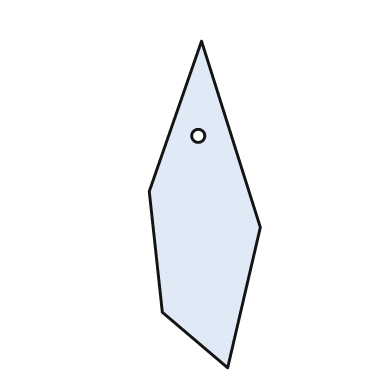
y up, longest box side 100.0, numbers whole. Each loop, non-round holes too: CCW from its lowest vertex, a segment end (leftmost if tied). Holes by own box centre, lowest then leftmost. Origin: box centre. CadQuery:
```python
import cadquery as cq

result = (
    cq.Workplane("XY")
    .moveTo(7.0, -50.0)
    .lineTo(17.0, -7.0)
    .lineTo(-1.0, 50.0)
    .lineTo(-17.0, 4.0)
    .lineTo(-13.0, -33.0)
    .close()
    .moveTo(-2.0, 21.0)
    .circle(2.0)
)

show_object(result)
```